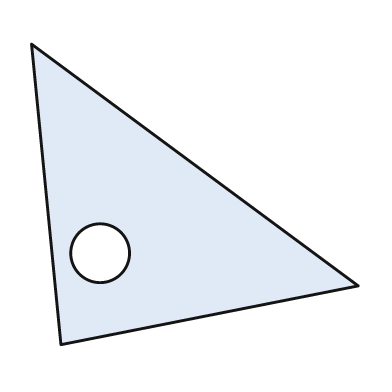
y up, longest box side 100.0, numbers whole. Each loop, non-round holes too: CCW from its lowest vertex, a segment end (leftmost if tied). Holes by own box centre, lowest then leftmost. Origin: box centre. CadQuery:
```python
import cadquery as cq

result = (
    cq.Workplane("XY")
    .moveTo(-41.0, -46.0)
    .lineTo(50.0, -28.0)
    .lineTo(-50.0, 46.0)
    .close()
    .moveTo(-29.0, -18.0)
    .circle(9.0)
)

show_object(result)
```